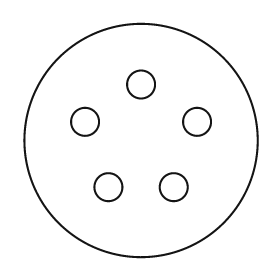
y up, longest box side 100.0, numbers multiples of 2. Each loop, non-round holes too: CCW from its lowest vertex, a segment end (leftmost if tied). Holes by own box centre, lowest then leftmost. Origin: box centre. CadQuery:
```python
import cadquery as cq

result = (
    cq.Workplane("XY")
    .moveTo(0.0, 0.0)
    .circle(50.0)
    .moveTo(-14.0, -20.0)
    .circle(6.0)
    .moveTo(14.0, -20.0)
    .circle(6.0)
    .moveTo(-24.0, 8.0)
    .circle(6.0)
    .moveTo(24.0, 8.0)
    .circle(6.0)
    .moveTo(0.0, 24.0)
    .circle(6.0)
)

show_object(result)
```